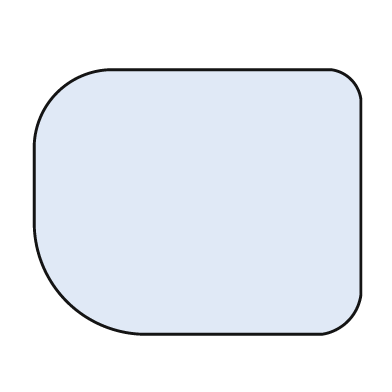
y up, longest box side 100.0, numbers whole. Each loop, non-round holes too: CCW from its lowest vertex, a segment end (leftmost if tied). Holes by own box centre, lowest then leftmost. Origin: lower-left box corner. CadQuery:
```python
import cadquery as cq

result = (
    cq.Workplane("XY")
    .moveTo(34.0, 0.0)
    .lineTo(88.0, 0.0)
    .threePointArc((96.0, 4.0), (100.0, 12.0))
    .lineTo(100.0, 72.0)
    .threePointArc((97.0, 78.0), (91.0, 81.0))
    .lineTo(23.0, 81.0)
    .threePointArc((7.0, 74.0), (0.0, 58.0))
    .lineTo(0.0, 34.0)
    .threePointArc((10.0, 10.0), (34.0, 0.0))
    .close()
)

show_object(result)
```